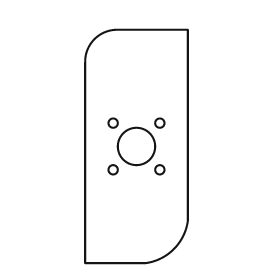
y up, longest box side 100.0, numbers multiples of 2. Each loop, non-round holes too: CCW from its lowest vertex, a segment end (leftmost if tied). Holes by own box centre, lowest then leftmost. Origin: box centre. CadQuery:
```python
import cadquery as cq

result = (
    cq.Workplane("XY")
    .moveTo(-22.0, -50.0)
    .lineTo(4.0, -50.0)
    .threePointArc((16.0, -44.0), (22.0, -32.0))
    .lineTo(22.0, 50.0)
    .lineTo(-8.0, 50.0)
    .threePointArc((-18.0, 46.0), (-22.0, 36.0))
    .close()
    .moveTo(-10.0, -10.0)
    .circle(2.0)
    .moveTo(10.0, -10.0)
    .circle(2.0)
    .moveTo(0.0, 0.0)
    .circle(8.0)
    .moveTo(-10.0, 10.0)
    .circle(2.0)
    .moveTo(10.0, 10.0)
    .circle(2.0)
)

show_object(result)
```